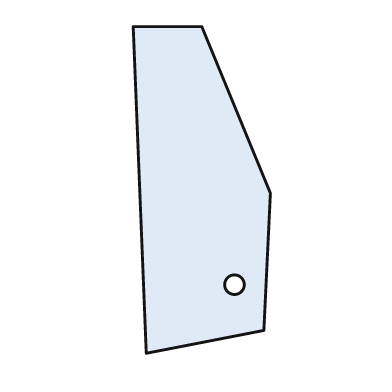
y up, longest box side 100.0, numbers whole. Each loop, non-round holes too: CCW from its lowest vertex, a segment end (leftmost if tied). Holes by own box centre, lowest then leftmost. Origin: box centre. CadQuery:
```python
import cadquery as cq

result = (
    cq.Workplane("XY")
    .moveTo(-17.0, -50.0)
    .lineTo(19.0, -43.0)
    .lineTo(21.0, -1.0)
    .lineTo(0.0, 50.0)
    .lineTo(-21.0, 50.0)
    .close()
    .moveTo(10.0, -29.0)
    .circle(3.0)
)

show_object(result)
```